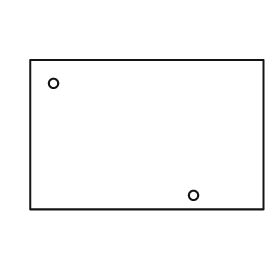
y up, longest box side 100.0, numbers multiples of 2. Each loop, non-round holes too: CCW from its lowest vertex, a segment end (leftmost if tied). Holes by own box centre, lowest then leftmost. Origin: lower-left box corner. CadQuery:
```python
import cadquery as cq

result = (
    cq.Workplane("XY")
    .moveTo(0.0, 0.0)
    .lineTo(100.0, 0.0)
    .lineTo(100.0, 64.0)
    .lineTo(0.0, 64.0)
    .close()
    .moveTo(70.0, 6.0)
    .circle(2.0)
    .moveTo(10.0, 54.0)
    .circle(2.0)
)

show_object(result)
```